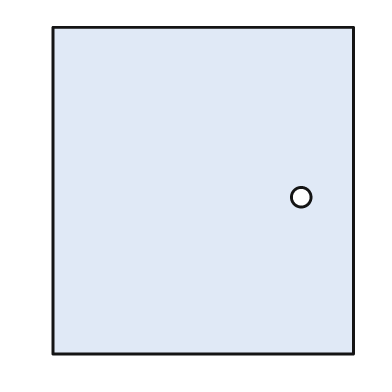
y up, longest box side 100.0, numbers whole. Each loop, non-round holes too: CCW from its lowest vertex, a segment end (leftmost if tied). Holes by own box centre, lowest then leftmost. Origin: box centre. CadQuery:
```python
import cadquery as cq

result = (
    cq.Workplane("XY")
    .moveTo(-46.0, -50.0)
    .lineTo(46.0, -50.0)
    .lineTo(46.0, 50.0)
    .lineTo(-46.0, 50.0)
    .close()
    .moveTo(30.0, -2.0)
    .circle(3.0)
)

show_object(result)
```